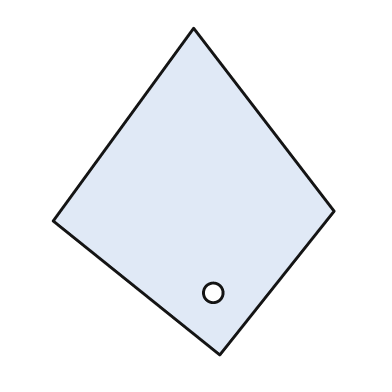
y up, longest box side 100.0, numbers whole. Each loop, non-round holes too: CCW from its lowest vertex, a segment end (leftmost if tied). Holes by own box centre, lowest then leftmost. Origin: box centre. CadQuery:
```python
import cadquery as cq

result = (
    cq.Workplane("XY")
    .moveTo(8.0, -50.0)
    .lineTo(43.0, -6.0)
    .lineTo(0.0, 50.0)
    .lineTo(-43.0, -9.0)
    .close()
    .moveTo(6.0, -31.0)
    .circle(3.0)
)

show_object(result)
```